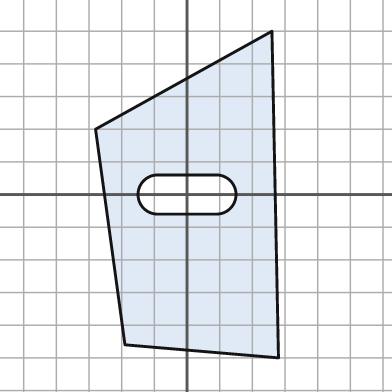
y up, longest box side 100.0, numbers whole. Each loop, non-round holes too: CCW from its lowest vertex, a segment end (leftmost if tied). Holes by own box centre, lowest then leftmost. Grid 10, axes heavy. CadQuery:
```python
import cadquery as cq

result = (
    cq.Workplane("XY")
    .moveTo(28.0, -50.0)
    .lineTo(26.0, 50.0)
    .lineTo(-28.0, 20.0)
    .lineTo(-19.0, -46.0)
    .close()
    .moveTo(-9.0, -6.0)
    .lineTo(9.0, -6.0)
    .threePointArc((15.0, 0.0), (9.0, 6.0))
    .lineTo(-9.0, 6.0)
    .threePointArc((-15.0, 0.0), (-9.0, -6.0))
    .close()
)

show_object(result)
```